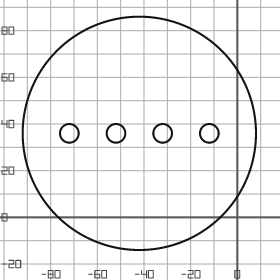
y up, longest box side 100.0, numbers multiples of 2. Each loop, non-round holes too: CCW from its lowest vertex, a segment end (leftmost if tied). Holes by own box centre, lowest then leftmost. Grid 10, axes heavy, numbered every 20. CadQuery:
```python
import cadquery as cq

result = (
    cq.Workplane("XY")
    .moveTo(-42.0, 36.0)
    .circle(50.0)
    .moveTo(-72.0, 36.0)
    .circle(4.0)
    .moveTo(-52.0, 36.0)
    .circle(4.0)
    .moveTo(-32.0, 36.0)
    .circle(4.0)
    .moveTo(-12.0, 36.0)
    .circle(4.0)
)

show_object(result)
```